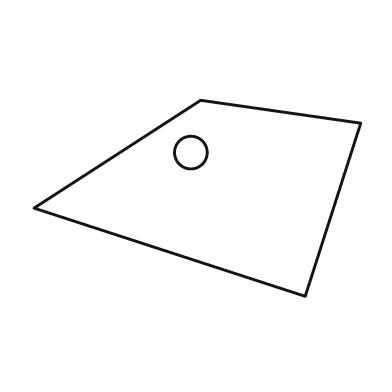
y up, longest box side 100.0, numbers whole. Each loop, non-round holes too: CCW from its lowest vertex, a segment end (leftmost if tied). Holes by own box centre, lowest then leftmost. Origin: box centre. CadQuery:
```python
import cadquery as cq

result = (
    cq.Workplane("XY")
    .moveTo(33.0, -30.0)
    .lineTo(50.0, 23.0)
    .lineTo(1.0, 30.0)
    .lineTo(-50.0, -3.0)
    .close()
    .moveTo(-2.0, 14.0)
    .circle(5.0)
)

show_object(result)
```